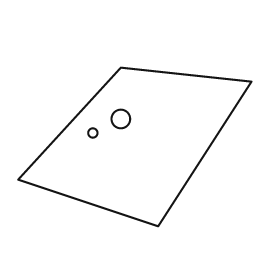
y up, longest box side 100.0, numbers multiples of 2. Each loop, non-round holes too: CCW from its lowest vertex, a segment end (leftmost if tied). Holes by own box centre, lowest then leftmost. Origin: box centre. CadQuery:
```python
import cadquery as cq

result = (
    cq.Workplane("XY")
    .moveTo(10.0, -34.0)
    .lineTo(50.0, 28.0)
    .lineTo(-6.0, 34.0)
    .lineTo(-50.0, -14.0)
    .close()
    .moveTo(-18.0, 6.0)
    .circle(2.0)
    .moveTo(-6.0, 12.0)
    .circle(4.0)
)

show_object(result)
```